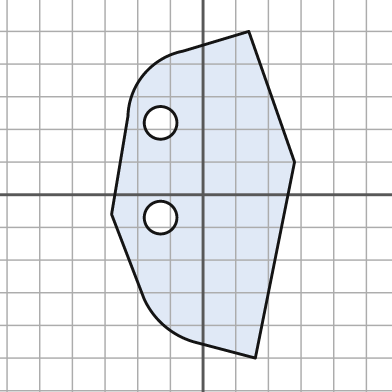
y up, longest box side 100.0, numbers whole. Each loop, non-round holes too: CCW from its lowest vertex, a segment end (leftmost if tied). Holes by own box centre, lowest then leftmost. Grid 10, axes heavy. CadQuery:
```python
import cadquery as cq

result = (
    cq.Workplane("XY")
    .moveTo(16.0, -50.0)
    .lineTo(28.0, 10.0)
    .lineTo(14.0, 50.0)
    .lineTo(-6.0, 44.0)
    .threePointArc((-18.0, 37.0), (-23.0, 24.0))
    .lineTo(-28.0, -6.0)
    .lineTo(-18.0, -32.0)
    .threePointArc((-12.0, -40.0), (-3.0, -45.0))
    .close()
    .moveTo(-13.0, -7.0)
    .circle(5.0)
    .moveTo(-13.0, 22.0)
    .circle(5.0)
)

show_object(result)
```